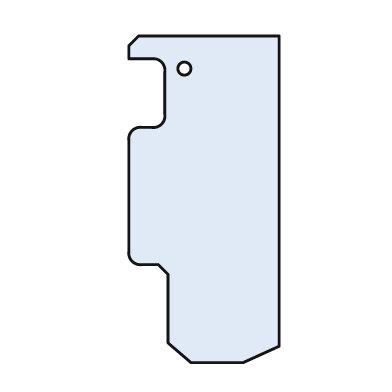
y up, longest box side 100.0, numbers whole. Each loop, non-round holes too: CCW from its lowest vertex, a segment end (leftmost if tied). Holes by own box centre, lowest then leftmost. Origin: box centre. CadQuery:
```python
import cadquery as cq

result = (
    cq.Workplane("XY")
    .moveTo(-4.0, -50.0)
    .lineTo(12.0, -50.0)
    .lineTo(23.0, -45.0)
    .lineTo(23.0, 50.0)
    .lineTo(-20.0, 50.0)
    .lineTo(-23.0, 47.0)
    .lineTo(-23.0, 43.0)
    .lineTo(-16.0, 43.0)
    .threePointArc((-13.0, 42.0), (-12.0, 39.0))
    .lineTo(-12.0, 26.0)
    .threePointArc((-13.0, 23.0), (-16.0, 22.0))
    .lineTo(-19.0, 22.0)
    .threePointArc((-22.0, 21.0), (-23.0, 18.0))
    .lineTo(-23.0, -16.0)
    .threePointArc((-22.0, -19.0), (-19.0, -20.0))
    .lineTo(-14.0, -20.0)
    .lineTo(-11.0, -23.0)
    .lineTo(-11.0, -44.0)
    .close()
    .moveTo(-6.0, 40.0)
    .circle(2.0)
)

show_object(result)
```